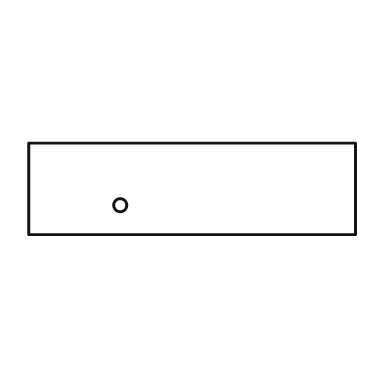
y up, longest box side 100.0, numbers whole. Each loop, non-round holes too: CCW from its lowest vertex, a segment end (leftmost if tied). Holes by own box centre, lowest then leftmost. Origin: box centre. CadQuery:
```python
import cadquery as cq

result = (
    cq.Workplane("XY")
    .moveTo(-50.0, -14.0)
    .lineTo(50.0, -14.0)
    .lineTo(50.0, 14.0)
    .lineTo(-50.0, 14.0)
    .close()
    .moveTo(-22.0, -5.0)
    .circle(2.0)
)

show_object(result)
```